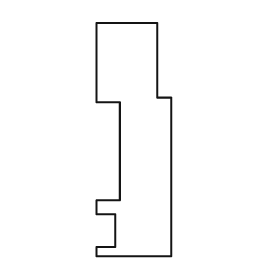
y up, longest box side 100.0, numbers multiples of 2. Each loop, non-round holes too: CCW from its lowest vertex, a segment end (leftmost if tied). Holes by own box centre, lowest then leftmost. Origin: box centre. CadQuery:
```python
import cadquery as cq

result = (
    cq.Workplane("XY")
    .moveTo(-16.0, -50.0)
    .lineTo(16.0, -50.0)
    .lineTo(16.0, 18.0)
    .lineTo(10.0, 18.0)
    .lineTo(10.0, 50.0)
    .lineTo(-16.0, 50.0)
    .lineTo(-16.0, 16.0)
    .lineTo(-6.0, 16.0)
    .lineTo(-6.0, -26.0)
    .lineTo(-16.0, -26.0)
    .lineTo(-16.0, -32.0)
    .lineTo(-8.0, -32.0)
    .lineTo(-8.0, -46.0)
    .lineTo(-16.0, -46.0)
    .close()
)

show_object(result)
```